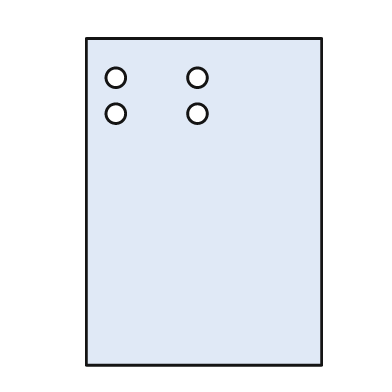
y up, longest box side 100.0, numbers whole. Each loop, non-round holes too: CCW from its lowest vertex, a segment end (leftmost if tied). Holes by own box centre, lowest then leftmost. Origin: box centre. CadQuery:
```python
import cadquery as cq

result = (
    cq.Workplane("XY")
    .moveTo(-36.0, -50.0)
    .lineTo(36.0, -50.0)
    .lineTo(36.0, 50.0)
    .lineTo(-36.0, 50.0)
    .close()
    .moveTo(-27.0, 27.0)
    .circle(3.0)
    .moveTo(-2.0, 27.0)
    .circle(3.0)
    .moveTo(-27.0, 38.0)
    .circle(3.0)
    .moveTo(-2.0, 38.0)
    .circle(3.0)
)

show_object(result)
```